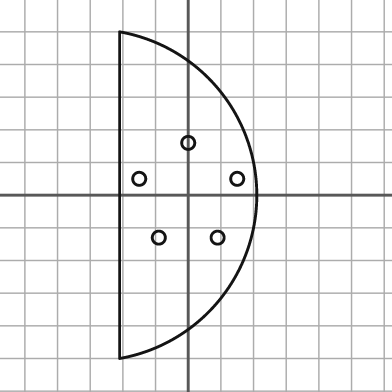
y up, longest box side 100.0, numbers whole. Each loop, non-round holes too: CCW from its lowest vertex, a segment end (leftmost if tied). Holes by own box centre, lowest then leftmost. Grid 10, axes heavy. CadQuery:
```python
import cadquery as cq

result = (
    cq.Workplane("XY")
    .moveTo(-21.0, -50.0)
    .threePointArc((21.0, 0.0), (-21.0, 50.0))
    .close()
    .moveTo(-9.0, -13.0)
    .circle(2.0)
    .moveTo(9.0, -13.0)
    .circle(2.0)
    .moveTo(-15.0, 5.0)
    .circle(2.0)
    .moveTo(15.0, 5.0)
    .circle(2.0)
    .moveTo(0.0, 16.0)
    .circle(2.0)
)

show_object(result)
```